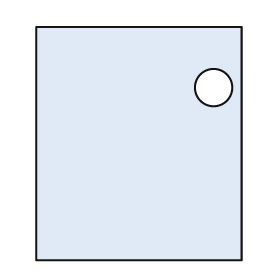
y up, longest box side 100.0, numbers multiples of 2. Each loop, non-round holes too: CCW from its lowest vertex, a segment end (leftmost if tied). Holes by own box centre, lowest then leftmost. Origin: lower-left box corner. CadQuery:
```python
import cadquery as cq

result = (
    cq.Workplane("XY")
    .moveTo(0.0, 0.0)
    .lineTo(88.0, 0.0)
    .lineTo(88.0, 100.0)
    .lineTo(0.0, 100.0)
    .close()
    .moveTo(76.0, 74.0)
    .circle(8.0)
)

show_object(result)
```